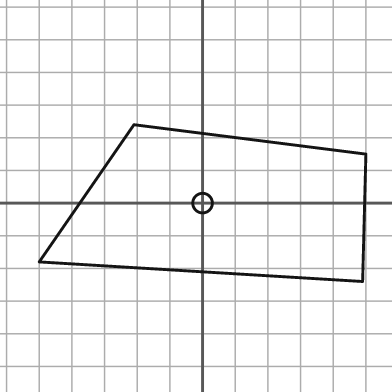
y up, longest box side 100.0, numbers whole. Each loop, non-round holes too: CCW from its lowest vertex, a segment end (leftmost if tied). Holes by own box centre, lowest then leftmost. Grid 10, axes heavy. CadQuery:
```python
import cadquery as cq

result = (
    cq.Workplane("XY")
    .moveTo(49.0, -24.0)
    .lineTo(50.0, 15.0)
    .lineTo(-21.0, 24.0)
    .lineTo(-50.0, -18.0)
    .close()
    .moveTo(0.0, 0.0)
    .circle(3.0)
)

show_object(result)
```